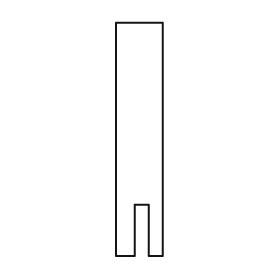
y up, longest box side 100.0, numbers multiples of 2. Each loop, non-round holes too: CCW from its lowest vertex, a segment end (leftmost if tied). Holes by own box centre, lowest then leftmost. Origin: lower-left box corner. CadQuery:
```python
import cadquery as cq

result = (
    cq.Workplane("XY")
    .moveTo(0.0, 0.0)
    .lineTo(8.0, 0.0)
    .lineTo(8.0, 22.0)
    .lineTo(14.0, 22.0)
    .lineTo(14.0, 0.0)
    .lineTo(20.0, 0.0)
    .lineTo(20.0, 100.0)
    .lineTo(0.0, 100.0)
    .close()
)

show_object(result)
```